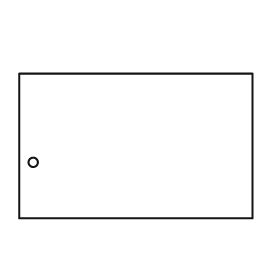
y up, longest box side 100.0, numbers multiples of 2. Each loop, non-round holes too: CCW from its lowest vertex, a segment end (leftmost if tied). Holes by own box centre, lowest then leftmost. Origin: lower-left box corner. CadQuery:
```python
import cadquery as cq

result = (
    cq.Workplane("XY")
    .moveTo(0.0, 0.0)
    .lineTo(100.0, 0.0)
    .lineTo(100.0, 62.0)
    .lineTo(0.0, 62.0)
    .close()
    .moveTo(6.0, 24.0)
    .circle(2.0)
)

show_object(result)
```